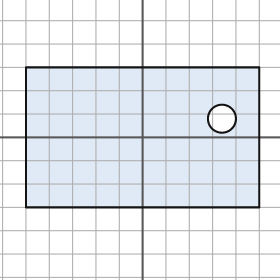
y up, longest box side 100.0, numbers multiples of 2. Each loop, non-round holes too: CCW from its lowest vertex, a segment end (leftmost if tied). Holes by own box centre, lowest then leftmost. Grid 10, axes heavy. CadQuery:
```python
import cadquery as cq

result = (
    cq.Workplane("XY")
    .moveTo(-50.0, -30.0)
    .lineTo(50.0, -30.0)
    .lineTo(50.0, 30.0)
    .lineTo(-50.0, 30.0)
    .close()
    .moveTo(34.0, 8.0)
    .circle(6.0)
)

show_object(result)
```